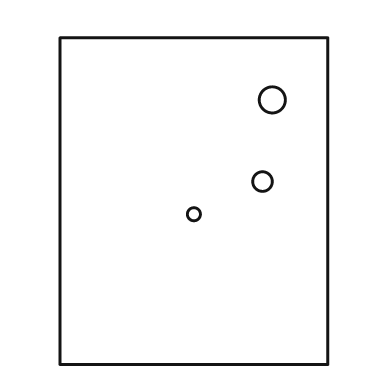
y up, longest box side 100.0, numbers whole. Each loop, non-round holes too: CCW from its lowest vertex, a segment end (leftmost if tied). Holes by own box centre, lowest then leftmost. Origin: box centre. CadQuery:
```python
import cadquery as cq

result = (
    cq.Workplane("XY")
    .moveTo(-41.0, -50.0)
    .lineTo(41.0, -50.0)
    .lineTo(41.0, 50.0)
    .lineTo(-41.0, 50.0)
    .close()
    .moveTo(0.0, -4.0)
    .circle(2.0)
    .moveTo(21.0, 6.0)
    .circle(3.0)
    .moveTo(24.0, 31.0)
    .circle(4.0)
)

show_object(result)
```